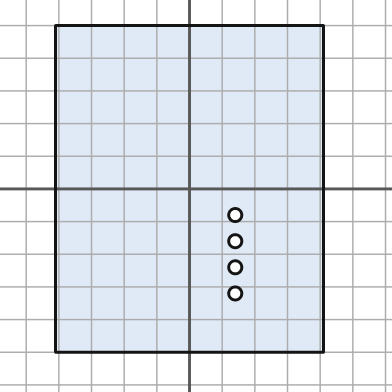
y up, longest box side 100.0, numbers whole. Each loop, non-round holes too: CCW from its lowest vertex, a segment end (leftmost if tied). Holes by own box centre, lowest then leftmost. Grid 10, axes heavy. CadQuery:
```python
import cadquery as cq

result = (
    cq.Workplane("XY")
    .moveTo(-41.0, -50.0)
    .lineTo(41.0, -50.0)
    .lineTo(41.0, 50.0)
    .lineTo(-41.0, 50.0)
    .close()
    .moveTo(14.0, -32.0)
    .circle(2.0)
    .moveTo(14.0, -24.0)
    .circle(2.0)
    .moveTo(14.0, -16.0)
    .circle(2.0)
    .moveTo(14.0, -8.0)
    .circle(2.0)
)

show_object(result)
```